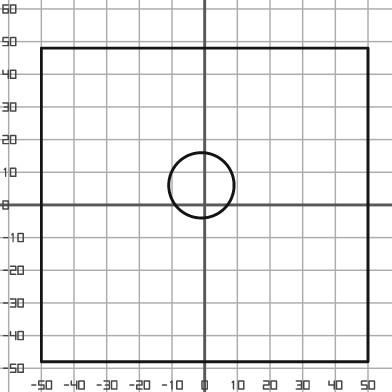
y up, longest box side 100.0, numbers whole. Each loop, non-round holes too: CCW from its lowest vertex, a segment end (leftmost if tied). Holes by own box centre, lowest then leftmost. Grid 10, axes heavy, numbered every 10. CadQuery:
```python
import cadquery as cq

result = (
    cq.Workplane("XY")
    .moveTo(-50.0, -48.0)
    .lineTo(50.0, -48.0)
    .lineTo(50.0, 48.0)
    .lineTo(-50.0, 48.0)
    .close()
    .moveTo(-1.0, 6.0)
    .circle(10.0)
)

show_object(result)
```